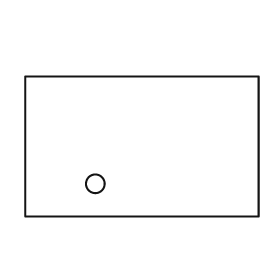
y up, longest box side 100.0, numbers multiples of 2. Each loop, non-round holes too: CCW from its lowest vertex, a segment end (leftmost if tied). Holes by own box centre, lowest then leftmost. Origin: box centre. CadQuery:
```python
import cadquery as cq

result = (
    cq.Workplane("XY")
    .moveTo(-50.0, -30.0)
    .lineTo(50.0, -30.0)
    .lineTo(50.0, 30.0)
    .lineTo(-50.0, 30.0)
    .close()
    .moveTo(-20.0, -16.0)
    .circle(4.0)
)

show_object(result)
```